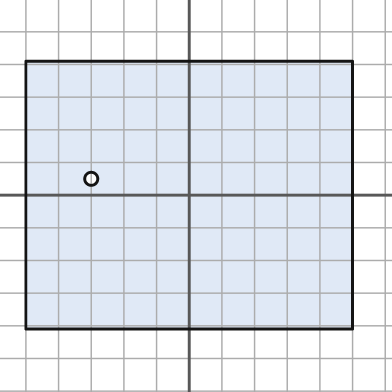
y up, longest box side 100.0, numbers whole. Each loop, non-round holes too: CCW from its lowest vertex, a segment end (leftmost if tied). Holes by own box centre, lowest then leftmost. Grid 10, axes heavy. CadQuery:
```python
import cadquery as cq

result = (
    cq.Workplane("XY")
    .moveTo(-50.0, -41.0)
    .lineTo(50.0, -41.0)
    .lineTo(50.0, 41.0)
    .lineTo(-50.0, 41.0)
    .close()
    .moveTo(-30.0, 5.0)
    .circle(2.0)
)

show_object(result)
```